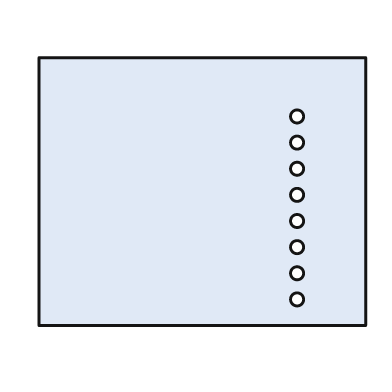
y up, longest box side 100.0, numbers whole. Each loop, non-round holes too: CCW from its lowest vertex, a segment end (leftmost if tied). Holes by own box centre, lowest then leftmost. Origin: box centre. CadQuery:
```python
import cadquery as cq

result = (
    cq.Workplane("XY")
    .moveTo(-50.0, -41.0)
    .lineTo(50.0, -41.0)
    .lineTo(50.0, 41.0)
    .lineTo(-50.0, 41.0)
    .close()
    .moveTo(29.0, -33.0)
    .circle(2.0)
    .moveTo(29.0, -25.0)
    .circle(2.0)
    .moveTo(29.0, -17.0)
    .circle(2.0)
    .moveTo(29.0, -9.0)
    .circle(2.0)
    .moveTo(29.0, -1.0)
    .circle(2.0)
    .moveTo(29.0, 7.0)
    .circle(2.0)
    .moveTo(29.0, 15.0)
    .circle(2.0)
    .moveTo(29.0, 23.0)
    .circle(2.0)
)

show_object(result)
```